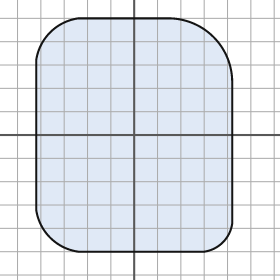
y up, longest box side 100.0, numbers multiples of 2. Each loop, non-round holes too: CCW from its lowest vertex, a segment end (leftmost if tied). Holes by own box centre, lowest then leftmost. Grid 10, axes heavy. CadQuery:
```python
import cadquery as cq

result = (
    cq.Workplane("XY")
    .moveTo(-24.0, -50.0)
    .lineTo(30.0, -50.0)
    .threePointArc((38.0, -46.0), (42.0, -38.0))
    .lineTo(42.0, 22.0)
    .threePointArc((34.0, 42.0), (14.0, 50.0))
    .lineTo(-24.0, 50.0)
    .threePointArc((-36.0, 44.0), (-42.0, 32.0))
    .lineTo(-42.0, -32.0)
    .threePointArc((-36.0, -44.0), (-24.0, -50.0))
    .close()
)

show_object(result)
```